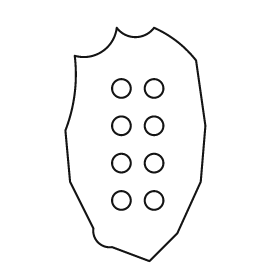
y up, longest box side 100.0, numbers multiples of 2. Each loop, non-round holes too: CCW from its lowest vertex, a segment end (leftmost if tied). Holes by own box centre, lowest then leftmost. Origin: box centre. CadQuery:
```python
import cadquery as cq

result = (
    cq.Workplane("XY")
    .moveTo(6.0, -50.0)
    .lineTo(18.0, -38.0)
    .lineTo(28.0, -16.0)
    .lineTo(30.0, 8.0)
    .lineTo(26.0, 36.0)
    .threePointArc((18.0, 44.0), (8.0, 50.0))
    .threePointArc((0.0, 46.0), (-8.0, 50.0))
    .threePointArc((-14.0, 40.0), (-26.0, 38.0))
    .threePointArc((-26.0, 22.0), (-30.0, 6.0))
    .lineTo(-28.0, -16.0)
    .lineTo(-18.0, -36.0)
    .threePointArc((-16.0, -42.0), (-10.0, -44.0))
    .close()
    .moveTo(-6.0, -24.0)
    .circle(4.0)
    .moveTo(8.0, -24.0)
    .circle(4.0)
    .moveTo(-6.0, -8.0)
    .circle(4.0)
    .moveTo(8.0, -8.0)
    .circle(4.0)
    .moveTo(-6.0, 8.0)
    .circle(4.0)
    .moveTo(8.0, 8.0)
    .circle(4.0)
    .moveTo(-6.0, 24.0)
    .circle(4.0)
    .moveTo(8.0, 24.0)
    .circle(4.0)
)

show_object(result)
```